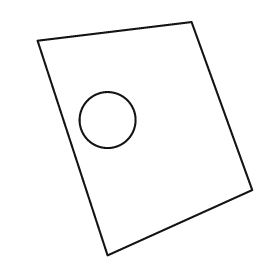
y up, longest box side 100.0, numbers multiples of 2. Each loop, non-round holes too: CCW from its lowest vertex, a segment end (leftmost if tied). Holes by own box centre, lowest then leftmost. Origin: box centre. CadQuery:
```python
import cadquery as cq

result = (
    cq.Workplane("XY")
    .moveTo(-16.0, -50.0)
    .lineTo(46.0, -22.0)
    .lineTo(20.0, 50.0)
    .lineTo(-46.0, 42.0)
    .close()
    .moveTo(-16.0, 8.0)
    .circle(12.0)
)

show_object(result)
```